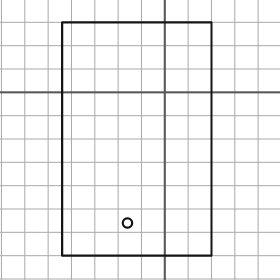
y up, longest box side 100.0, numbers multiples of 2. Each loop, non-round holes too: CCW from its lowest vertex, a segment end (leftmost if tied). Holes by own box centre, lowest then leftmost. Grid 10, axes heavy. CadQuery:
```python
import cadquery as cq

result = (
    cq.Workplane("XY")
    .moveTo(-44.0, -70.0)
    .lineTo(20.0, -70.0)
    .lineTo(20.0, 30.0)
    .lineTo(-44.0, 30.0)
    .close()
    .moveTo(-16.0, -56.0)
    .circle(2.0)
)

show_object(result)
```